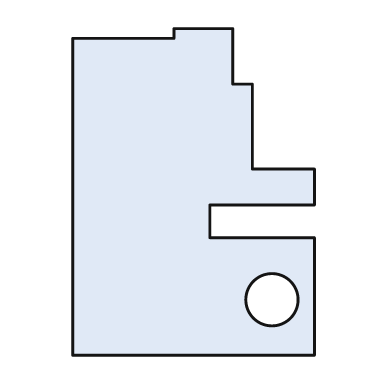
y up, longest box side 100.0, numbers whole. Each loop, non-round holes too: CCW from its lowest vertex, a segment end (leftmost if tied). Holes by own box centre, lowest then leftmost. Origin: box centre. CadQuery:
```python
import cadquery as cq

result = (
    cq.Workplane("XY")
    .moveTo(-37.0, -50.0)
    .lineTo(37.0, -50.0)
    .lineTo(37.0, -14.0)
    .lineTo(5.0, -14.0)
    .lineTo(5.0, -4.0)
    .lineTo(37.0, -4.0)
    .lineTo(37.0, 7.0)
    .lineTo(18.0, 7.0)
    .lineTo(18.0, 33.0)
    .lineTo(12.0, 33.0)
    .lineTo(12.0, 50.0)
    .lineTo(-6.0, 50.0)
    .lineTo(-6.0, 47.0)
    .lineTo(-37.0, 47.0)
    .close()
    .moveTo(24.0, -33.0)
    .circle(8.0)
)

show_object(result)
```